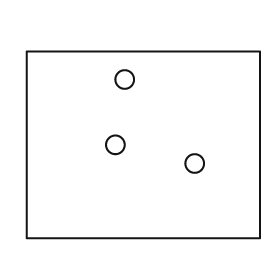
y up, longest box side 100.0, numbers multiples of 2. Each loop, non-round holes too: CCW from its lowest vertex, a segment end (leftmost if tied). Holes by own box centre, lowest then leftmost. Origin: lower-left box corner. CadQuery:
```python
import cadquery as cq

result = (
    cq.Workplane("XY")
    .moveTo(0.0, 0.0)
    .lineTo(100.0, 0.0)
    .lineTo(100.0, 80.0)
    .lineTo(0.0, 80.0)
    .close()
    .moveTo(72.0, 32.0)
    .circle(4.0)
    .moveTo(38.0, 40.0)
    .circle(4.0)
    .moveTo(42.0, 68.0)
    .circle(4.0)
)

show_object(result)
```